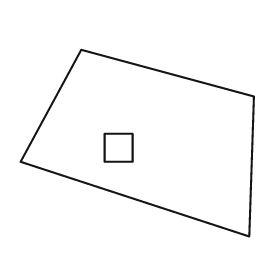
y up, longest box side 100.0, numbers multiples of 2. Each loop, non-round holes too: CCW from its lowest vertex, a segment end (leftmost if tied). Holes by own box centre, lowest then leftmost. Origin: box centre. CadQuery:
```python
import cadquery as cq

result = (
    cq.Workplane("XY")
    .moveTo(48.0, -40.0)
    .lineTo(50.0, 20.0)
    .lineTo(-24.0, 40.0)
    .lineTo(-50.0, -8.0)
    .close()
    .moveTo(-14.0, -8.0)
    .lineTo(-2.0, -8.0)
    .lineTo(-2.0, 4.0)
    .lineTo(-14.0, 4.0)
    .close()
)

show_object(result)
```